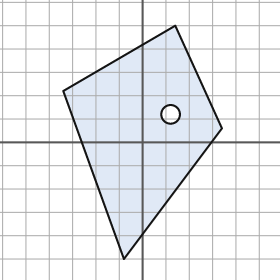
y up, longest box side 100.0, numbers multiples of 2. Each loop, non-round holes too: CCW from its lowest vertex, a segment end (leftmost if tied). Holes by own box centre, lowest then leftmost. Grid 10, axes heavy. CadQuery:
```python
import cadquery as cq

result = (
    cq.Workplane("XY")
    .moveTo(-8.0, -50.0)
    .lineTo(34.0, 6.0)
    .lineTo(14.0, 50.0)
    .lineTo(-34.0, 22.0)
    .close()
    .moveTo(12.0, 12.0)
    .circle(4.0)
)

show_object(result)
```